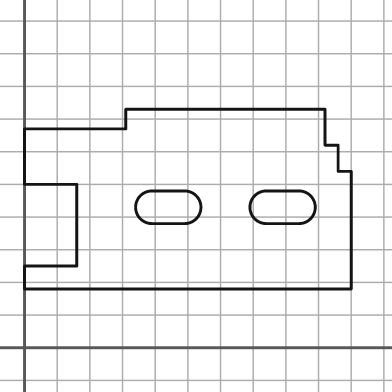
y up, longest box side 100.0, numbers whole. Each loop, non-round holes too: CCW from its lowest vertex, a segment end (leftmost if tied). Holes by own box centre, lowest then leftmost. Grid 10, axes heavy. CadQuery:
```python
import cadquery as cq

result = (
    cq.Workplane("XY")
    .moveTo(0.0, 18.0)
    .lineTo(100.0, 18.0)
    .lineTo(100.0, 54.0)
    .lineTo(96.0, 54.0)
    .lineTo(96.0, 62.0)
    .lineTo(92.0, 62.0)
    .lineTo(92.0, 73.0)
    .lineTo(31.0, 73.0)
    .lineTo(31.0, 67.0)
    .lineTo(0.0, 67.0)
    .lineTo(0.0, 50.0)
    .lineTo(16.0, 50.0)
    .lineTo(16.0, 25.0)
    .lineTo(0.0, 25.0)
    .close()
    .moveTo(39.0, 38.0)
    .lineTo(49.0, 38.0)
    .threePointArc((54.0, 43.0), (49.0, 48.0))
    .lineTo(39.0, 48.0)
    .threePointArc((34.0, 43.0), (39.0, 38.0))
    .close()
    .moveTo(74.0, 38.0)
    .lineTo(84.0, 38.0)
    .threePointArc((89.0, 43.0), (84.0, 48.0))
    .lineTo(74.0, 48.0)
    .threePointArc((69.0, 43.0), (74.0, 38.0))
    .close()
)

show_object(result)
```